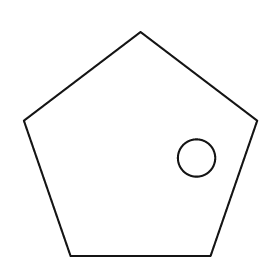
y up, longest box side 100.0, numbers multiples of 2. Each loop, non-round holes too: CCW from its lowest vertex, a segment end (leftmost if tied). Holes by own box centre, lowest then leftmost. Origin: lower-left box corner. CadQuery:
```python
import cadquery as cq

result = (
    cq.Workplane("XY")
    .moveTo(20.0, 0.0)
    .lineTo(80.0, 0.0)
    .lineTo(100.0, 58.0)
    .lineTo(50.0, 96.0)
    .lineTo(0.0, 58.0)
    .close()
    .moveTo(74.0, 42.0)
    .circle(8.0)
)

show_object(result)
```